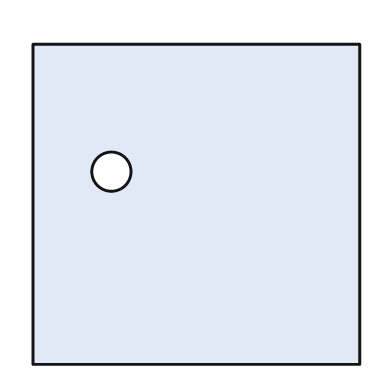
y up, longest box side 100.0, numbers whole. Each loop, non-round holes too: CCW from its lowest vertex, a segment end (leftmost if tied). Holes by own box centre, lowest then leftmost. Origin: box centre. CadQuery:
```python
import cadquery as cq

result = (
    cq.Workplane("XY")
    .moveTo(-50.0, -49.0)
    .lineTo(50.0, -49.0)
    .lineTo(50.0, 49.0)
    .lineTo(-50.0, 49.0)
    .close()
    .moveTo(-26.0, 10.0)
    .circle(6.0)
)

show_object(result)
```